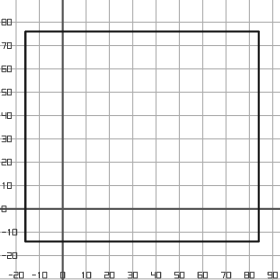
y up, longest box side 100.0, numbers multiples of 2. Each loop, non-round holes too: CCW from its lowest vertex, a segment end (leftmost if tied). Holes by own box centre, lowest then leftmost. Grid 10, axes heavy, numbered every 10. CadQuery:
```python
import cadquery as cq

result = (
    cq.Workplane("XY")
    .moveTo(-16.0, -14.0)
    .lineTo(84.0, -14.0)
    .lineTo(84.0, 76.0)
    .lineTo(-16.0, 76.0)
    .close()
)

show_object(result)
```